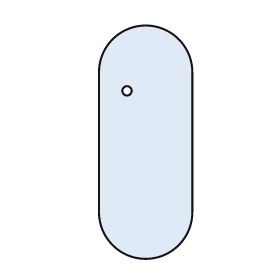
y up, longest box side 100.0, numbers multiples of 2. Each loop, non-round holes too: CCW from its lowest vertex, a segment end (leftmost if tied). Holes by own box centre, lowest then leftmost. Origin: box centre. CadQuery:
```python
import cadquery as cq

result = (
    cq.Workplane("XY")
    .moveTo(-20.0, -30.0)
    .threePointArc((0.0, -50.0), (20.0, -30.0))
    .lineTo(20.0, 30.0)
    .threePointArc((0.0, 50.0), (-20.0, 30.0))
    .close()
    .moveTo(-8.0, 22.0)
    .circle(2.0)
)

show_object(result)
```